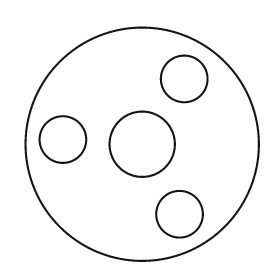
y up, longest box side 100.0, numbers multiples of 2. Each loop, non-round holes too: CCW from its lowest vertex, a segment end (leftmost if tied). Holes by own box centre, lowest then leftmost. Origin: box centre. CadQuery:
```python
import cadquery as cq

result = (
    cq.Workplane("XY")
    .moveTo(0.0, 0.0)
    .circle(50.0)
    .moveTo(16.0, -30.0)
    .circle(10.0)
    .moveTo(0.0, 0.0)
    .circle(14.0)
    .moveTo(-34.0, 2.0)
    .circle(10.0)
    .moveTo(18.0, 28.0)
    .circle(10.0)
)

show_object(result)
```